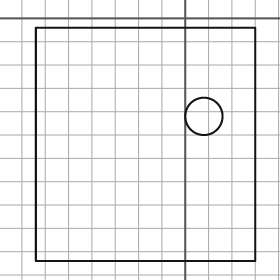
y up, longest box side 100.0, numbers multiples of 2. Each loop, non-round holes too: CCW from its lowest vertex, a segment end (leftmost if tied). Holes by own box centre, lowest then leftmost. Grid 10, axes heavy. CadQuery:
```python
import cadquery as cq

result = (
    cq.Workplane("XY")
    .moveTo(-64.0, -104.0)
    .lineTo(30.0, -104.0)
    .lineTo(30.0, -4.0)
    .lineTo(-64.0, -4.0)
    .close()
    .moveTo(8.0, -42.0)
    .circle(8.0)
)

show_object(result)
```